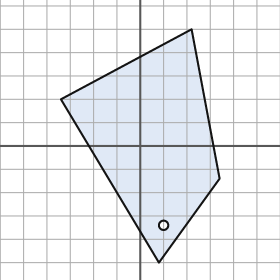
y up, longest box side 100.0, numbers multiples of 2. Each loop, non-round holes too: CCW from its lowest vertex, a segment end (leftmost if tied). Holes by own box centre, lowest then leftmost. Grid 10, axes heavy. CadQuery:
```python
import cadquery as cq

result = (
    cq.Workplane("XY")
    .moveTo(8.0, -50.0)
    .lineTo(34.0, -14.0)
    .lineTo(22.0, 50.0)
    .lineTo(-34.0, 20.0)
    .close()
    .moveTo(10.0, -34.0)
    .circle(2.0)
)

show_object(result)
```